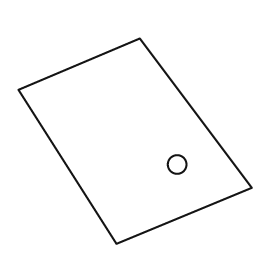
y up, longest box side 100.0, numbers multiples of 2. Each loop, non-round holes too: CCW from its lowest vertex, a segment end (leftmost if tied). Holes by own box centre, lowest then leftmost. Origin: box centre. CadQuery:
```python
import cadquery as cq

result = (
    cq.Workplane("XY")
    .moveTo(-8.0, -44.0)
    .lineTo(50.0, -20.0)
    .lineTo(2.0, 44.0)
    .lineTo(-50.0, 22.0)
    .close()
    .moveTo(18.0, -10.0)
    .circle(4.0)
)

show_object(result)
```